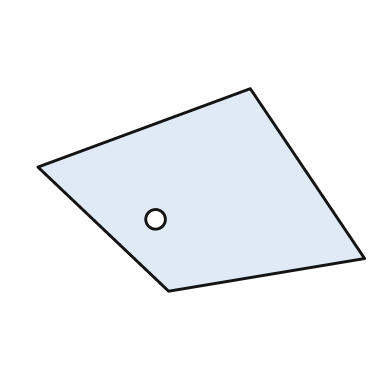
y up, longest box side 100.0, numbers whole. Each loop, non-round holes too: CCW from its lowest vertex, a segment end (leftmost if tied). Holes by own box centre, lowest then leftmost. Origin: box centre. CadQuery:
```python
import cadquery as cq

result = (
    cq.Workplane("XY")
    .moveTo(-10.0, -31.0)
    .lineTo(50.0, -21.0)
    .lineTo(15.0, 31.0)
    .lineTo(-50.0, 7.0)
    .close()
    .moveTo(-14.0, -9.0)
    .circle(3.0)
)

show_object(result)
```